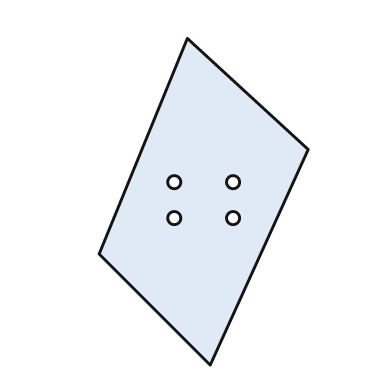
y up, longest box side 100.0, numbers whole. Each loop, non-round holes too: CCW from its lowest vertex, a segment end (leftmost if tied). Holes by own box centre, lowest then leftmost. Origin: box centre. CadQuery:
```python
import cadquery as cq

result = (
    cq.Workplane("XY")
    .moveTo(2.0, -50.0)
    .lineTo(32.0, 16.0)
    .lineTo(-5.0, 50.0)
    .lineTo(-32.0, -16.0)
    .close()
    .moveTo(-9.0, -5.0)
    .circle(2.0)
    .moveTo(9.0, -5.0)
    .circle(2.0)
    .moveTo(-9.0, 6.0)
    .circle(2.0)
    .moveTo(9.0, 6.0)
    .circle(2.0)
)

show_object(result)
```